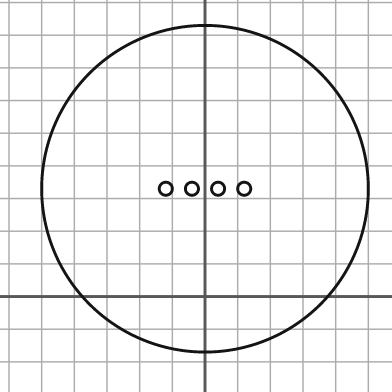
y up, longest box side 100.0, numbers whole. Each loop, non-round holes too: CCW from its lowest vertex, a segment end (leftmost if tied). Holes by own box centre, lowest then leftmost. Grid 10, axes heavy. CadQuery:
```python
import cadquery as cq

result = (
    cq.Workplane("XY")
    .moveTo(0.0, 33.0)
    .circle(50.0)
    .moveTo(-12.0, 33.0)
    .circle(2.0)
    .moveTo(-4.0, 33.0)
    .circle(2.0)
    .moveTo(4.0, 33.0)
    .circle(2.0)
    .moveTo(12.0, 33.0)
    .circle(2.0)
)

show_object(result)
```